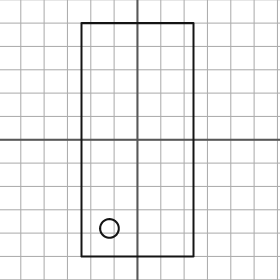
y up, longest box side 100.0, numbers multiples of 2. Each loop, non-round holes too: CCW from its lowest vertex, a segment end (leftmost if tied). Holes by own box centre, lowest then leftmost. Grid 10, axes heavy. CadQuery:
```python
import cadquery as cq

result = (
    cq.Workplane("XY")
    .moveTo(-24.0, -50.0)
    .lineTo(24.0, -50.0)
    .lineTo(24.0, 50.0)
    .lineTo(-24.0, 50.0)
    .close()
    .moveTo(-12.0, -38.0)
    .circle(4.0)
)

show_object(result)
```